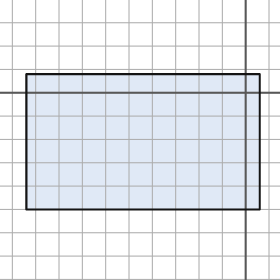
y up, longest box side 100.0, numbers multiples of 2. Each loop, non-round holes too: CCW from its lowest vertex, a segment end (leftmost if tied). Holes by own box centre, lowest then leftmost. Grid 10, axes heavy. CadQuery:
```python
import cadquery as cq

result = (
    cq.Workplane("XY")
    .moveTo(-94.0, -50.0)
    .lineTo(6.0, -50.0)
    .lineTo(6.0, 8.0)
    .lineTo(-94.0, 8.0)
    .close()
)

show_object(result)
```